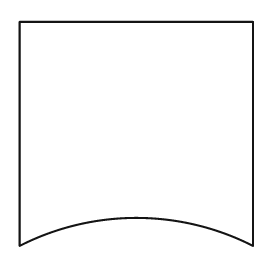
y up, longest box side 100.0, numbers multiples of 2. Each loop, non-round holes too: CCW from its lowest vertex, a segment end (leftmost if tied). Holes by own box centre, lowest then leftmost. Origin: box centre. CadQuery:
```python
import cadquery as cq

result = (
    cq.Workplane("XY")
    .moveTo(-50.0, -48.0)
    .threePointArc((0.0, -36.0), (50.0, -48.0))
    .lineTo(50.0, 48.0)
    .lineTo(-50.0, 48.0)
    .close()
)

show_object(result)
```